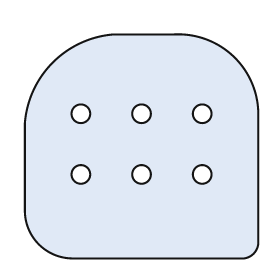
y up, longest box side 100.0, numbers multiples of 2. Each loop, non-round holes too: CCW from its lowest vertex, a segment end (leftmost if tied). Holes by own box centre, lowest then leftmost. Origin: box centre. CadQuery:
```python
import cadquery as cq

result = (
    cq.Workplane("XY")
    .moveTo(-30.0, -48.0)
    .lineTo(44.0, -48.0)
    .threePointArc((48.0, -46.0), (50.0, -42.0))
    .lineTo(50.0, 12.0)
    .threePointArc((40.0, 38.0), (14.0, 48.0))
    .lineTo(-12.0, 48.0)
    .threePointArc((-38.0, 36.0), (-50.0, 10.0))
    .lineTo(-50.0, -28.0)
    .threePointArc((-44.0, -42.0), (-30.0, -48.0))
    .close()
    .moveTo(-26.0, -12.0)
    .circle(4.0)
    .moveTo(0.0, -12.0)
    .circle(4.0)
    .moveTo(26.0, -12.0)
    .circle(4.0)
    .moveTo(-26.0, 14.0)
    .circle(4.0)
    .moveTo(0.0, 14.0)
    .circle(4.0)
    .moveTo(26.0, 14.0)
    .circle(4.0)
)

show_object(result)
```